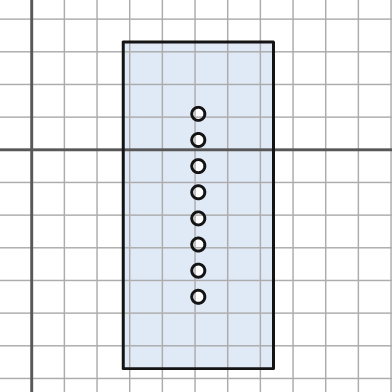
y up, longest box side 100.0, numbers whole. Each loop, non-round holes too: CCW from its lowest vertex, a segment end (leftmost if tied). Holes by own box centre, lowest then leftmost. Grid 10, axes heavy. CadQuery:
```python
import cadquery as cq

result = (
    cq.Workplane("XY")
    .moveTo(28.0, -67.0)
    .lineTo(74.0, -67.0)
    .lineTo(74.0, 33.0)
    .lineTo(28.0, 33.0)
    .close()
    .moveTo(51.0, -45.0)
    .circle(2.0)
    .moveTo(51.0, -37.0)
    .circle(2.0)
    .moveTo(51.0, -29.0)
    .circle(2.0)
    .moveTo(51.0, -21.0)
    .circle(2.0)
    .moveTo(51.0, -13.0)
    .circle(2.0)
    .moveTo(51.0, -5.0)
    .circle(2.0)
    .moveTo(51.0, 3.0)
    .circle(2.0)
    .moveTo(51.0, 11.0)
    .circle(2.0)
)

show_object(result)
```